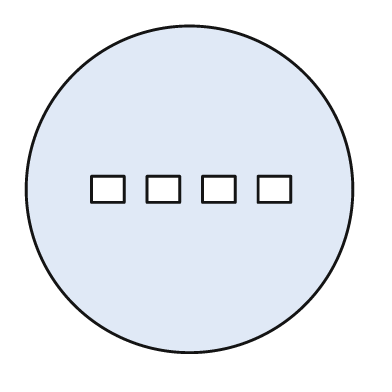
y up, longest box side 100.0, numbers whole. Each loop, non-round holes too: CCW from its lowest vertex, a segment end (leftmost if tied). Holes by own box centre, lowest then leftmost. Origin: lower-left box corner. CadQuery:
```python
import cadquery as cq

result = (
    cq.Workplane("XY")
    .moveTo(50.0, 50.0)
    .circle(50.0)
    .moveTo(20.0, 46.0)
    .lineTo(30.0, 46.0)
    .lineTo(30.0, 54.0)
    .lineTo(20.0, 54.0)
    .close()
    .moveTo(37.0, 46.0)
    .lineTo(47.0, 46.0)
    .lineTo(47.0, 54.0)
    .lineTo(37.0, 54.0)
    .close()
    .moveTo(54.0, 46.0)
    .lineTo(64.0, 46.0)
    .lineTo(64.0, 54.0)
    .lineTo(54.0, 54.0)
    .close()
    .moveTo(71.0, 46.0)
    .lineTo(81.0, 46.0)
    .lineTo(81.0, 54.0)
    .lineTo(71.0, 54.0)
    .close()
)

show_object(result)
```